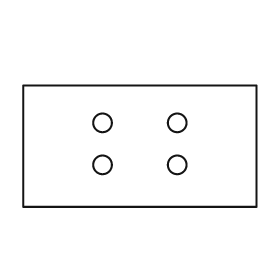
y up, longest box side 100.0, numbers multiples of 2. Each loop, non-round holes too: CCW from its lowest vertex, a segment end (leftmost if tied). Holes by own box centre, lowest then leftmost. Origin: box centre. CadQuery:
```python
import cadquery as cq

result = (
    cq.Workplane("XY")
    .moveTo(-50.0, -26.0)
    .lineTo(50.0, -26.0)
    .lineTo(50.0, 26.0)
    .lineTo(-50.0, 26.0)
    .close()
    .moveTo(-16.0, -8.0)
    .circle(4.0)
    .moveTo(16.0, -8.0)
    .circle(4.0)
    .moveTo(-16.0, 10.0)
    .circle(4.0)
    .moveTo(16.0, 10.0)
    .circle(4.0)
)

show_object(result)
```